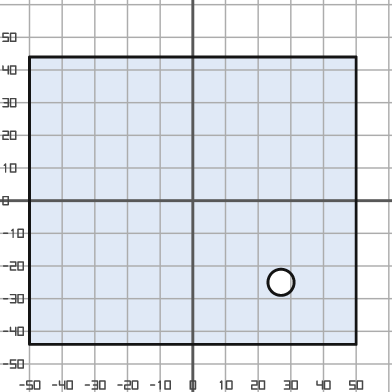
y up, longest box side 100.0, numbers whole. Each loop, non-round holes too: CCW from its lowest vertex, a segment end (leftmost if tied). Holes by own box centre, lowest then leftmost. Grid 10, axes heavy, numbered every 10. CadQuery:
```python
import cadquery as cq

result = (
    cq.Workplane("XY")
    .moveTo(-50.0, -44.0)
    .lineTo(50.0, -44.0)
    .lineTo(50.0, 44.0)
    .lineTo(-50.0, 44.0)
    .close()
    .moveTo(27.0, -25.0)
    .circle(4.0)
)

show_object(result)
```